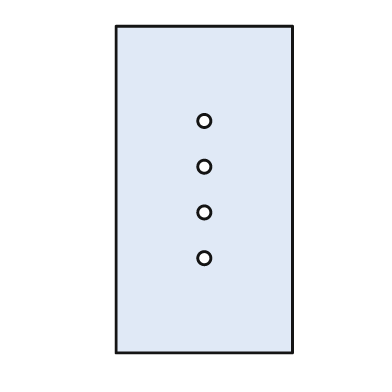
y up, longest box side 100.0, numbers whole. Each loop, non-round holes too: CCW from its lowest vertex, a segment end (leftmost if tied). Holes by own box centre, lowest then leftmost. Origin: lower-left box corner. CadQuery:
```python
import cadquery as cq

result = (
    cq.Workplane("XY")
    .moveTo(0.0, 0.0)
    .lineTo(54.0, 0.0)
    .lineTo(54.0, 100.0)
    .lineTo(0.0, 100.0)
    .close()
    .moveTo(27.0, 29.0)
    .circle(2.0)
    .moveTo(27.0, 43.0)
    .circle(2.0)
    .moveTo(27.0, 57.0)
    .circle(2.0)
    .moveTo(27.0, 71.0)
    .circle(2.0)
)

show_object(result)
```